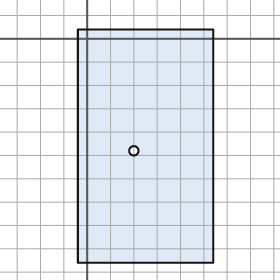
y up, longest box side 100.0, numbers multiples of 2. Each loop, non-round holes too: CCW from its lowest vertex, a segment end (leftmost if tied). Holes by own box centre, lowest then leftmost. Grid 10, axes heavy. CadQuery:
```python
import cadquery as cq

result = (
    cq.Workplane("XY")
    .moveTo(-4.0, -96.0)
    .lineTo(54.0, -96.0)
    .lineTo(54.0, 4.0)
    .lineTo(-4.0, 4.0)
    .close()
    .moveTo(20.0, -48.0)
    .circle(2.0)
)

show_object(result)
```